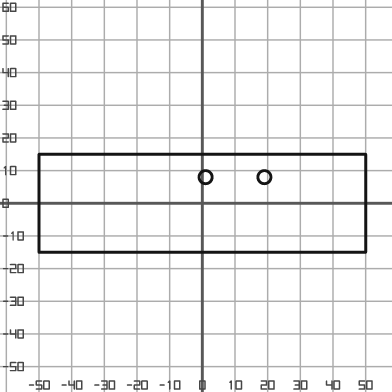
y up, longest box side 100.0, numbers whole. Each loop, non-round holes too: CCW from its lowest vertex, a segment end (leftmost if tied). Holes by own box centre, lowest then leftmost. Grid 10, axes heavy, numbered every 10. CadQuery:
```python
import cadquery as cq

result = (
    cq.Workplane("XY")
    .moveTo(-50.0, -15.0)
    .lineTo(50.0, -15.0)
    .lineTo(50.0, 15.0)
    .lineTo(-50.0, 15.0)
    .close()
    .moveTo(1.0, 8.0)
    .circle(2.0)
    .moveTo(19.0, 8.0)
    .circle(2.0)
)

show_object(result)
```